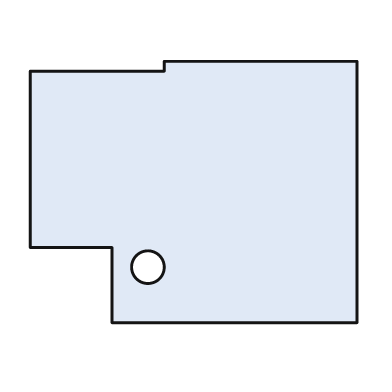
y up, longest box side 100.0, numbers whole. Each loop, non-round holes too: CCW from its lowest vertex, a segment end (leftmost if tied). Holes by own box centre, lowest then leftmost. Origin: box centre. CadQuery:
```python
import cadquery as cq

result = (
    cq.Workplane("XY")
    .moveTo(-25.0, -40.0)
    .lineTo(50.0, -40.0)
    .lineTo(50.0, 40.0)
    .lineTo(-9.0, 40.0)
    .lineTo(-9.0, 37.0)
    .lineTo(-50.0, 37.0)
    .lineTo(-50.0, -17.0)
    .lineTo(-25.0, -17.0)
    .close()
    .moveTo(-14.0, -23.0)
    .circle(5.0)
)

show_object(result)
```